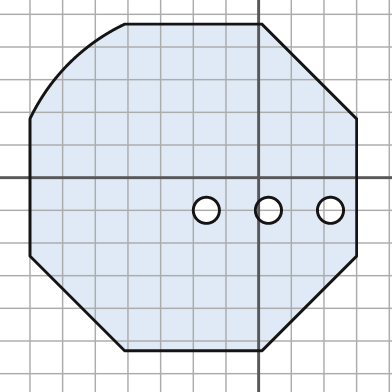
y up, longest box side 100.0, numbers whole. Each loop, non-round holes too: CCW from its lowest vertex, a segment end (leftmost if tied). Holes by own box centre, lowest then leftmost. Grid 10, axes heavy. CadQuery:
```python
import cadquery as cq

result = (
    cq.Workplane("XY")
    .moveTo(-41.0, -53.0)
    .lineTo(1.0, -53.0)
    .lineTo(30.0, -24.0)
    .lineTo(30.0, 18.0)
    .lineTo(1.0, 47.0)
    .lineTo(-41.0, 47.0)
    .threePointArc((-58.0, 35.0), (-70.0, 18.0))
    .lineTo(-70.0, -24.0)
    .close()
    .moveTo(-16.0, -10.0)
    .circle(4.0)
    .moveTo(3.0, -10.0)
    .circle(4.0)
    .moveTo(22.0, -10.0)
    .circle(4.0)
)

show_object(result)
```